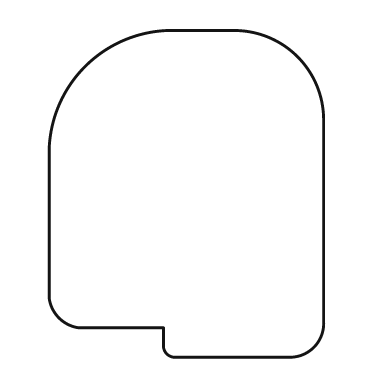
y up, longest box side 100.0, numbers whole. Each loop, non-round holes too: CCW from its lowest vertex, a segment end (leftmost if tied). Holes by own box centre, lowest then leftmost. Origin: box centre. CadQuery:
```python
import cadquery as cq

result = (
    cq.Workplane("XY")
    .moveTo(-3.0, -50.0)
    .lineTo(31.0, -50.0)
    .threePointArc((39.0, -47.0), (42.0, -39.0))
    .lineTo(42.0, 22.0)
    .threePointArc((34.0, 42.0), (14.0, 50.0))
    .lineTo(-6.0, 50.0)
    .threePointArc((-31.0, 39.0), (-42.0, 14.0))
    .lineTo(-42.0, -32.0)
    .threePointArc((-39.0, -38.0), (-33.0, -41.0))
    .lineTo(-7.0, -41.0)
    .lineTo(-7.0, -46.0)
    .threePointArc((-6.0, -49.0), (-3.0, -50.0))
    .close()
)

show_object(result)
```